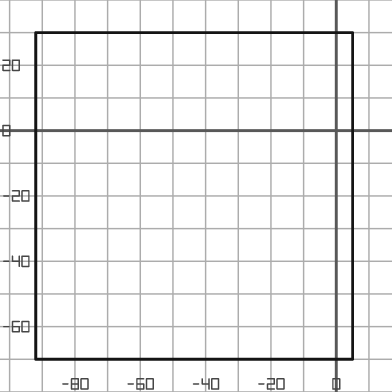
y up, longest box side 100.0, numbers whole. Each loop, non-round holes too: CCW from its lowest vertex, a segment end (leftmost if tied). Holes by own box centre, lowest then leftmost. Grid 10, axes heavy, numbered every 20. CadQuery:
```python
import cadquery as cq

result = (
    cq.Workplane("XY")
    .moveTo(-92.0, -70.0)
    .lineTo(5.0, -70.0)
    .lineTo(5.0, 30.0)
    .lineTo(-92.0, 30.0)
    .close()
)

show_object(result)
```